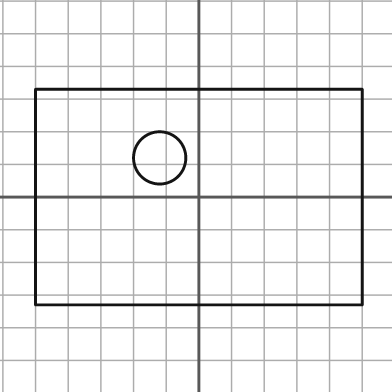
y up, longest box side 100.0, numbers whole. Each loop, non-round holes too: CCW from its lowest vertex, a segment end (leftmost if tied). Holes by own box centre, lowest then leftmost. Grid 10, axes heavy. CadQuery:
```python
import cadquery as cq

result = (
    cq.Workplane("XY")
    .moveTo(-50.0, -33.0)
    .lineTo(50.0, -33.0)
    .lineTo(50.0, 33.0)
    .lineTo(-50.0, 33.0)
    .close()
    .moveTo(-12.0, 12.0)
    .circle(8.0)
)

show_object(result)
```